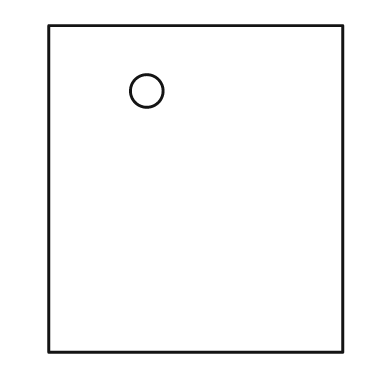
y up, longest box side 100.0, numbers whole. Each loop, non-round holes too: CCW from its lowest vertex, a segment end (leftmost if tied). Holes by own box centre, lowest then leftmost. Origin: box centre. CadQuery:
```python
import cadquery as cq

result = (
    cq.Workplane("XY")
    .moveTo(-45.0, -50.0)
    .lineTo(45.0, -50.0)
    .lineTo(45.0, 50.0)
    .lineTo(-45.0, 50.0)
    .close()
    .moveTo(-15.0, 30.0)
    .circle(5.0)
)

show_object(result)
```